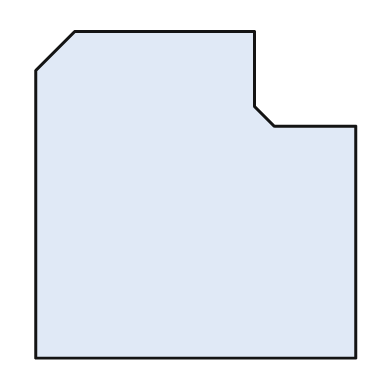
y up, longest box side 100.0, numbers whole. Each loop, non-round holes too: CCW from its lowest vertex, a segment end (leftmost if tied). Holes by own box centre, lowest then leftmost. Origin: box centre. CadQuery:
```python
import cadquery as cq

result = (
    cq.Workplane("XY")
    .moveTo(-49.0, -50.0)
    .lineTo(49.0, -50.0)
    .lineTo(49.0, 21.0)
    .lineTo(24.0, 21.0)
    .lineTo(18.0, 27.0)
    .lineTo(18.0, 50.0)
    .lineTo(-37.0, 50.0)
    .lineTo(-49.0, 38.0)
    .close()
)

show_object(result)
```